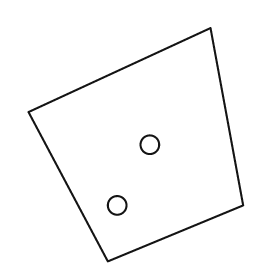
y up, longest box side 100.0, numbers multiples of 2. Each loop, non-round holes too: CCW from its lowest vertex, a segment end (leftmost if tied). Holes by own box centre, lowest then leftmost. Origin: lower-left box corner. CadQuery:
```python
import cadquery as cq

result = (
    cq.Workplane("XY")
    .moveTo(34.0, 0.0)
    .lineTo(92.0, 24.0)
    .lineTo(78.0, 100.0)
    .lineTo(0.0, 64.0)
    .close()
    .moveTo(38.0, 24.0)
    .circle(4.0)
    .moveTo(52.0, 50.0)
    .circle(4.0)
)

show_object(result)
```